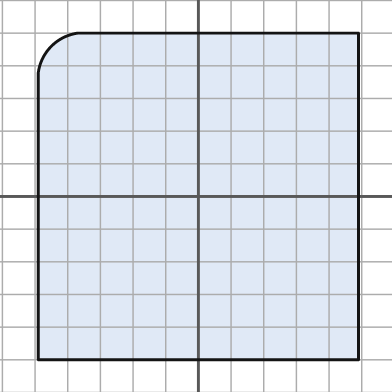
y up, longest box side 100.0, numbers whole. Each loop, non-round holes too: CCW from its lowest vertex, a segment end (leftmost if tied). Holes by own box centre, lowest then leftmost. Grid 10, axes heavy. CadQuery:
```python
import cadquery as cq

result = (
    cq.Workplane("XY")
    .moveTo(-49.0, -50.0)
    .lineTo(49.0, -50.0)
    .lineTo(49.0, 50.0)
    .lineTo(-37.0, 50.0)
    .threePointArc((-45.0, 46.0), (-49.0, 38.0))
    .close()
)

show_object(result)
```